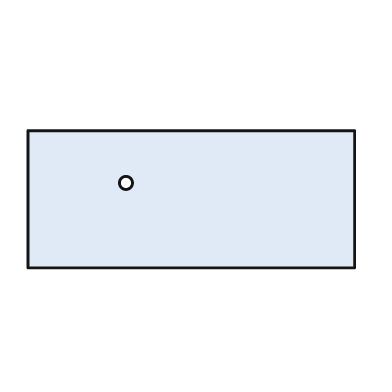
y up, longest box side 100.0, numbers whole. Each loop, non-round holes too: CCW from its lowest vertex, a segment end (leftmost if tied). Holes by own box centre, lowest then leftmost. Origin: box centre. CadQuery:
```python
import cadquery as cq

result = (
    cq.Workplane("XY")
    .moveTo(-50.0, -21.0)
    .lineTo(50.0, -21.0)
    .lineTo(50.0, 21.0)
    .lineTo(-50.0, 21.0)
    .close()
    .moveTo(-20.0, 5.0)
    .circle(2.0)
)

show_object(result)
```